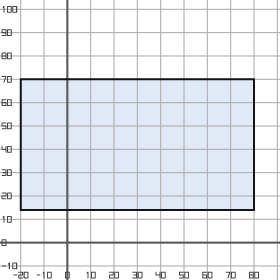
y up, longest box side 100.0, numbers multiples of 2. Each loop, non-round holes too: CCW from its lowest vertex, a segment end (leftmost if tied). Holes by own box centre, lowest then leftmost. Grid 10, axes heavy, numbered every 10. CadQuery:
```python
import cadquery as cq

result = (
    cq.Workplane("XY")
    .moveTo(-20.0, 14.0)
    .lineTo(80.0, 14.0)
    .lineTo(80.0, 70.0)
    .lineTo(-20.0, 70.0)
    .close()
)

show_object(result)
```